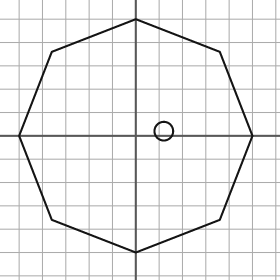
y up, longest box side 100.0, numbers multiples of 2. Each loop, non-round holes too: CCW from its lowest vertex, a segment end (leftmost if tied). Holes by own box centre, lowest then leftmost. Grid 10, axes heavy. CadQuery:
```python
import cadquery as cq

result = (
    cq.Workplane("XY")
    .moveTo(0.0, -50.0)
    .lineTo(36.0, -36.0)
    .lineTo(50.0, 0.0)
    .lineTo(36.0, 36.0)
    .lineTo(0.0, 50.0)
    .lineTo(-36.0, 36.0)
    .lineTo(-50.0, 0.0)
    .lineTo(-36.0, -36.0)
    .close()
    .moveTo(12.0, 2.0)
    .circle(4.0)
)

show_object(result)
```